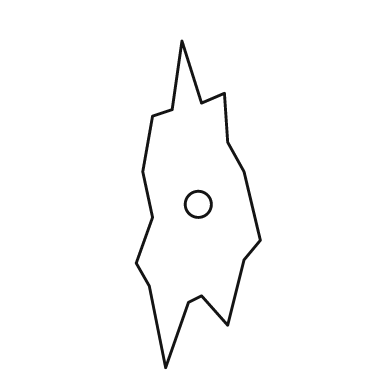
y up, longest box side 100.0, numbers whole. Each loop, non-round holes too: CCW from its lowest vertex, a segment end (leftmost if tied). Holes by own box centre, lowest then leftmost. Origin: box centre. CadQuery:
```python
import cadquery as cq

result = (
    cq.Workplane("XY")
    .moveTo(-10.0, -50.0)
    .lineTo(-3.0, -30.0)
    .lineTo(1.0, -28.0)
    .lineTo(9.0, -37.0)
    .lineTo(14.0, -17.0)
    .lineTo(19.0, -11.0)
    .lineTo(14.0, 10.0)
    .lineTo(9.0, 19.0)
    .lineTo(8.0, 34.0)
    .lineTo(1.0, 31.0)
    .lineTo(-5.0, 50.0)
    .lineTo(-8.0, 29.0)
    .lineTo(-14.0, 27.0)
    .lineTo(-17.0, 10.0)
    .lineTo(-14.0, -4.0)
    .lineTo(-19.0, -18.0)
    .lineTo(-15.0, -25.0)
    .close()
    .moveTo(0.0, 0.0)
    .circle(4.0)
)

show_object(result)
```